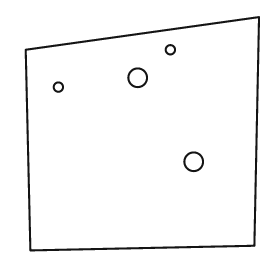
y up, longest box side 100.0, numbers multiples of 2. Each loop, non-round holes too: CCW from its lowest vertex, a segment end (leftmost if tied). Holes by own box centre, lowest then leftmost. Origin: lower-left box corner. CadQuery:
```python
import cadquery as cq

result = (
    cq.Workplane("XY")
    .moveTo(2.0, 0.0)
    .lineTo(98.0, 2.0)
    .lineTo(100.0, 100.0)
    .lineTo(0.0, 86.0)
    .close()
    .moveTo(72.0, 38.0)
    .circle(4.0)
    .moveTo(14.0, 70.0)
    .circle(2.0)
    .moveTo(48.0, 74.0)
    .circle(4.0)
    .moveTo(62.0, 86.0)
    .circle(2.0)
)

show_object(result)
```